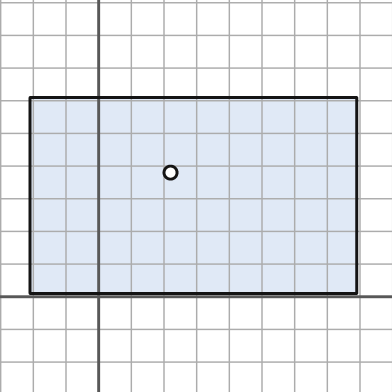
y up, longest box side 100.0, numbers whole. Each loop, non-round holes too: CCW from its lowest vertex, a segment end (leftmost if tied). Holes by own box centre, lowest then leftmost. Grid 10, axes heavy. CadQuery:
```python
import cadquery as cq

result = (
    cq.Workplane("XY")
    .moveTo(-21.0, 1.0)
    .lineTo(79.0, 1.0)
    .lineTo(79.0, 61.0)
    .lineTo(-21.0, 61.0)
    .close()
    .moveTo(22.0, 38.0)
    .circle(2.0)
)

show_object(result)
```